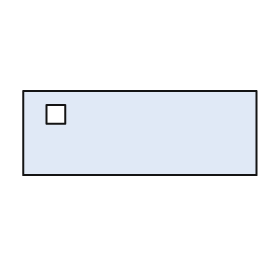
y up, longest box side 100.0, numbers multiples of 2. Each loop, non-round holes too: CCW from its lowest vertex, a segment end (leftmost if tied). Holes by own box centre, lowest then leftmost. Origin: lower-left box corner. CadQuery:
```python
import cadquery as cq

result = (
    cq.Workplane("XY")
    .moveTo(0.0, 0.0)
    .lineTo(100.0, 0.0)
    .lineTo(100.0, 36.0)
    .lineTo(0.0, 36.0)
    .close()
    .moveTo(10.0, 22.0)
    .lineTo(18.0, 22.0)
    .lineTo(18.0, 30.0)
    .lineTo(10.0, 30.0)
    .close()
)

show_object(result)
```